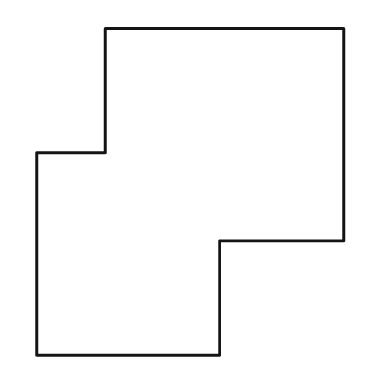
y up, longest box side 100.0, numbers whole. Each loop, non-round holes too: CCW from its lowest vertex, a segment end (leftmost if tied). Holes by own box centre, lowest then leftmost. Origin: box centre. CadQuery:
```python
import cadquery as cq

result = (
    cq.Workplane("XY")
    .moveTo(-47.0, -50.0)
    .lineTo(9.0, -50.0)
    .lineTo(9.0, -15.0)
    .lineTo(47.0, -15.0)
    .lineTo(47.0, 50.0)
    .lineTo(-26.0, 50.0)
    .lineTo(-26.0, 12.0)
    .lineTo(-47.0, 12.0)
    .close()
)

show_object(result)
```